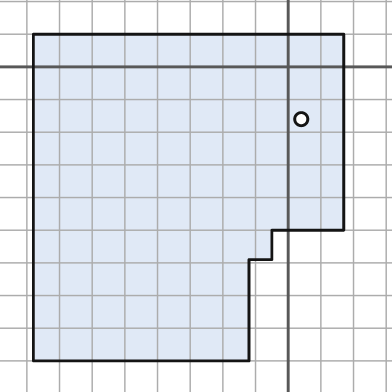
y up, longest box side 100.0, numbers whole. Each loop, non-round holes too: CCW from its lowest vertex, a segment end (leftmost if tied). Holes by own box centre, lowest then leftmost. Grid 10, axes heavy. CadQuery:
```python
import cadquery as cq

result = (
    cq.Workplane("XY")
    .moveTo(-78.0, -90.0)
    .lineTo(-12.0, -90.0)
    .lineTo(-12.0, -59.0)
    .lineTo(-5.0, -59.0)
    .lineTo(-5.0, -50.0)
    .lineTo(17.0, -50.0)
    .lineTo(17.0, 10.0)
    .lineTo(-78.0, 10.0)
    .close()
    .moveTo(4.0, -16.0)
    .circle(2.0)
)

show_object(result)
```